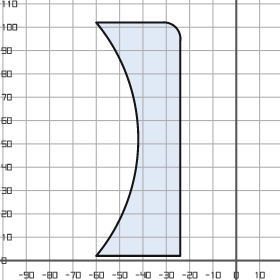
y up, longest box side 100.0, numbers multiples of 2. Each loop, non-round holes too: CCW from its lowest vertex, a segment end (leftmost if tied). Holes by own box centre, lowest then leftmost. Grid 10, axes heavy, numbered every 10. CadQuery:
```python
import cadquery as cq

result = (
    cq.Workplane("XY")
    .moveTo(-60.0, 2.0)
    .lineTo(-24.0, 2.0)
    .lineTo(-24.0, 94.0)
    .threePointArc((-26.0, 100.0), (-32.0, 102.0))
    .lineTo(-60.0, 102.0)
    .threePointArc((-42.0, 52.0), (-60.0, 2.0))
    .close()
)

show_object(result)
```